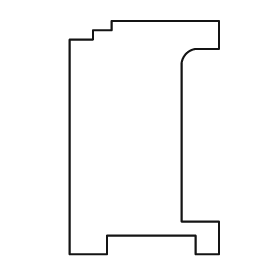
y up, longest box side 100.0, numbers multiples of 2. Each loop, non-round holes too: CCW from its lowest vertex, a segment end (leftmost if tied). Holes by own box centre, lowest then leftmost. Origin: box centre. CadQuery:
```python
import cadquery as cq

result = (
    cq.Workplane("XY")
    .moveTo(-32.0, -50.0)
    .lineTo(-16.0, -50.0)
    .lineTo(-16.0, -42.0)
    .lineTo(22.0, -42.0)
    .lineTo(22.0, -50.0)
    .lineTo(32.0, -50.0)
    .lineTo(32.0, -36.0)
    .lineTo(16.0, -36.0)
    .lineTo(16.0, 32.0)
    .threePointArc((18.0, 36.0), (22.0, 38.0))
    .lineTo(32.0, 38.0)
    .lineTo(32.0, 50.0)
    .lineTo(-14.0, 50.0)
    .lineTo(-14.0, 46.0)
    .lineTo(-22.0, 46.0)
    .lineTo(-22.0, 42.0)
    .lineTo(-32.0, 42.0)
    .close()
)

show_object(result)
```